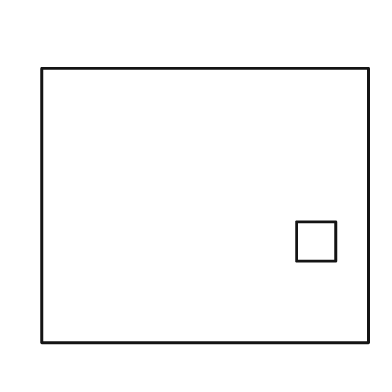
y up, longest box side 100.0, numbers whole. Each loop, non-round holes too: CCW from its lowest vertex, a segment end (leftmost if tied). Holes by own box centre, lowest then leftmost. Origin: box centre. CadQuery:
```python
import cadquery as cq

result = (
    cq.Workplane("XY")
    .moveTo(-50.0, -42.0)
    .lineTo(50.0, -42.0)
    .lineTo(50.0, 42.0)
    .lineTo(-50.0, 42.0)
    .close()
    .moveTo(28.0, -17.0)
    .lineTo(40.0, -17.0)
    .lineTo(40.0, -5.0)
    .lineTo(28.0, -5.0)
    .close()
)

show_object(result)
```